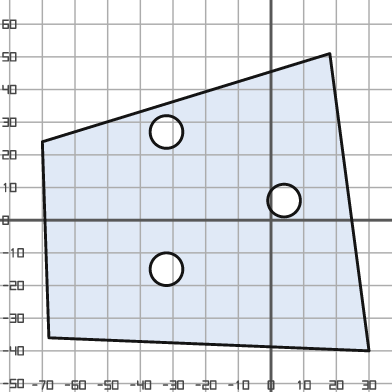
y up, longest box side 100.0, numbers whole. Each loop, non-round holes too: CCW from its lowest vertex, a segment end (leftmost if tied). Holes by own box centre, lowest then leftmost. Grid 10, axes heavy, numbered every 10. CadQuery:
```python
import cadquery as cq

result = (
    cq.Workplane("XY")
    .moveTo(30.0, -40.0)
    .lineTo(18.0, 51.0)
    .lineTo(-70.0, 24.0)
    .lineTo(-68.0, -36.0)
    .close()
    .moveTo(-32.0, -15.0)
    .circle(5.0)
    .moveTo(4.0, 6.0)
    .circle(5.0)
    .moveTo(-32.0, 27.0)
    .circle(5.0)
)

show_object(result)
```